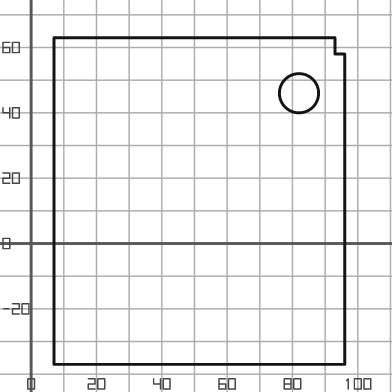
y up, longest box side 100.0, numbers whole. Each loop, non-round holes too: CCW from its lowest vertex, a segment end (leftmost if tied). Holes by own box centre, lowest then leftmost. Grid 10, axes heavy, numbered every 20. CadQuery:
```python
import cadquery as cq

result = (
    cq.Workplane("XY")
    .moveTo(7.0, -37.0)
    .lineTo(96.0, -37.0)
    .lineTo(96.0, 58.0)
    .lineTo(93.0, 58.0)
    .lineTo(93.0, 63.0)
    .lineTo(7.0, 63.0)
    .close()
    .moveTo(82.0, 46.0)
    .circle(6.0)
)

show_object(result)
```